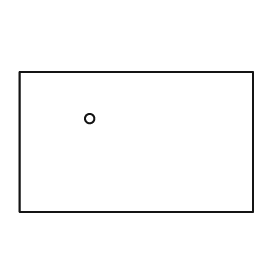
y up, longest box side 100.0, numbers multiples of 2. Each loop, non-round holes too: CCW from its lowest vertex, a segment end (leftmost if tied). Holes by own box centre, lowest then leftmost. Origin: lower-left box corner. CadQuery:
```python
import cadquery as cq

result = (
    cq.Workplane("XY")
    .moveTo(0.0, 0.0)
    .lineTo(100.0, 0.0)
    .lineTo(100.0, 60.0)
    .lineTo(0.0, 60.0)
    .close()
    .moveTo(30.0, 40.0)
    .circle(2.0)
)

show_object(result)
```